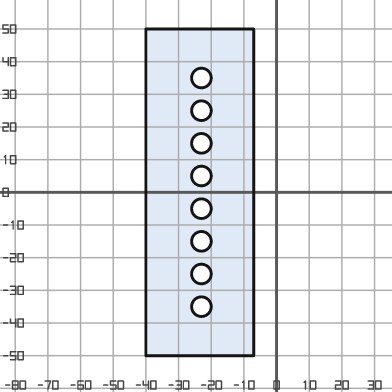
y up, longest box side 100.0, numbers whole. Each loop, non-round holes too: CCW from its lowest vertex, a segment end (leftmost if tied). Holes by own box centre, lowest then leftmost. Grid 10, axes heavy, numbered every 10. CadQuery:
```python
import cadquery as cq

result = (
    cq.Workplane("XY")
    .moveTo(-40.0, -50.0)
    .lineTo(-7.0, -50.0)
    .lineTo(-7.0, 50.0)
    .lineTo(-40.0, 50.0)
    .close()
    .moveTo(-23.0, -35.0)
    .circle(3.0)
    .moveTo(-23.0, -25.0)
    .circle(3.0)
    .moveTo(-23.0, -15.0)
    .circle(3.0)
    .moveTo(-23.0, -5.0)
    .circle(3.0)
    .moveTo(-23.0, 5.0)
    .circle(3.0)
    .moveTo(-23.0, 15.0)
    .circle(3.0)
    .moveTo(-23.0, 25.0)
    .circle(3.0)
    .moveTo(-23.0, 35.0)
    .circle(3.0)
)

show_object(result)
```